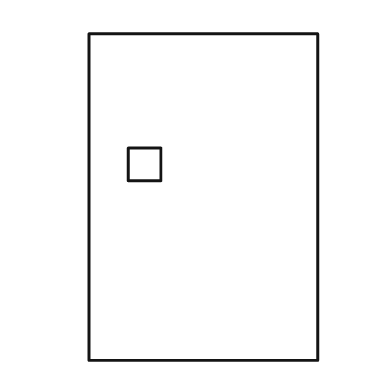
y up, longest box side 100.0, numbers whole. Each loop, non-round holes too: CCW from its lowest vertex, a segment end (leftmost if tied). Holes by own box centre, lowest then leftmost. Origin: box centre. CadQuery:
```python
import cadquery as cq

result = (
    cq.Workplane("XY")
    .moveTo(-35.0, -50.0)
    .lineTo(35.0, -50.0)
    .lineTo(35.0, 50.0)
    .lineTo(-35.0, 50.0)
    .close()
    .moveTo(-23.0, 5.0)
    .lineTo(-13.0, 5.0)
    .lineTo(-13.0, 15.0)
    .lineTo(-23.0, 15.0)
    .close()
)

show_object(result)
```